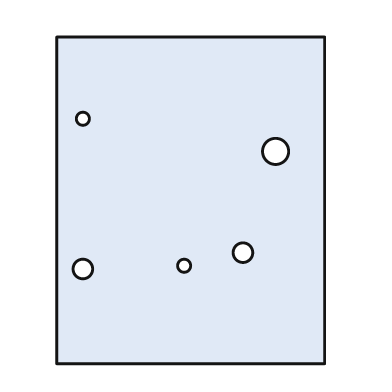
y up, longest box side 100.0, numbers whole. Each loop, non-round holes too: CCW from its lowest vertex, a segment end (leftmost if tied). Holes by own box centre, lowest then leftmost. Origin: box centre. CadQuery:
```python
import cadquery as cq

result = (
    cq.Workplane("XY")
    .moveTo(-41.0, -50.0)
    .lineTo(41.0, -50.0)
    .lineTo(41.0, 50.0)
    .lineTo(-41.0, 50.0)
    .close()
    .moveTo(-33.0, -21.0)
    .circle(3.0)
    .moveTo(-2.0, -20.0)
    .circle(2.0)
    .moveTo(16.0, -16.0)
    .circle(3.0)
    .moveTo(26.0, 15.0)
    .circle(4.0)
    .moveTo(-33.0, 25.0)
    .circle(2.0)
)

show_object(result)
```